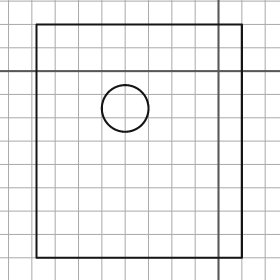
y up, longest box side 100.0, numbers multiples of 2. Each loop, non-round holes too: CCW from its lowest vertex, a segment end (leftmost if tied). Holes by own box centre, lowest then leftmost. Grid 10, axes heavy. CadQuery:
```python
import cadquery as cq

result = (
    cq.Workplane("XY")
    .moveTo(-78.0, -80.0)
    .lineTo(10.0, -80.0)
    .lineTo(10.0, 20.0)
    .lineTo(-78.0, 20.0)
    .close()
    .moveTo(-40.0, -16.0)
    .circle(10.0)
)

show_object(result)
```